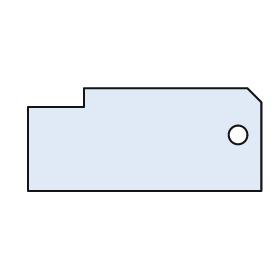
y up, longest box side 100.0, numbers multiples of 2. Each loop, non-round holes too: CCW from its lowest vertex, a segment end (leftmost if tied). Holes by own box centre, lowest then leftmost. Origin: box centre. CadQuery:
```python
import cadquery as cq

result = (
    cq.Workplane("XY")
    .moveTo(-50.0, -22.0)
    .lineTo(50.0, -22.0)
    .lineTo(50.0, 16.0)
    .lineTo(44.0, 22.0)
    .lineTo(-26.0, 22.0)
    .lineTo(-26.0, 14.0)
    .lineTo(-50.0, 14.0)
    .close()
    .moveTo(40.0, 2.0)
    .circle(4.0)
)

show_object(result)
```